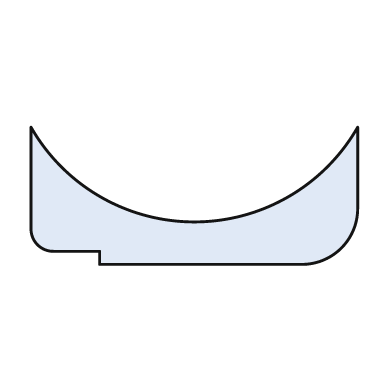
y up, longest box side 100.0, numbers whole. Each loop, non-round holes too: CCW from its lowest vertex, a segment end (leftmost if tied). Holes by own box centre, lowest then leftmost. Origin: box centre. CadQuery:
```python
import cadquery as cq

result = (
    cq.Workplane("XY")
    .moveTo(-29.0, -21.0)
    .lineTo(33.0, -21.0)
    .threePointArc((45.0, -16.0), (50.0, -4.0))
    .lineTo(50.0, 21.0)
    .threePointArc((0.0, -8.0), (-50.0, 21.0))
    .lineTo(-50.0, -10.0)
    .threePointArc((-48.0, -15.0), (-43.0, -17.0))
    .lineTo(-29.0, -17.0)
    .close()
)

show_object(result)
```